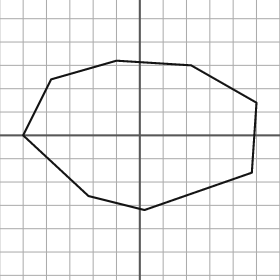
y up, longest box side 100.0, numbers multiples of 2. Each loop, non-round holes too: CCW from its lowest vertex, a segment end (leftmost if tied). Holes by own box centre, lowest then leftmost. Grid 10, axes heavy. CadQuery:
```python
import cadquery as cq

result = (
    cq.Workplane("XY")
    .moveTo(2.0, -32.0)
    .lineTo(48.0, -16.0)
    .lineTo(50.0, 14.0)
    .lineTo(22.0, 30.0)
    .lineTo(-10.0, 32.0)
    .lineTo(-38.0, 24.0)
    .lineTo(-50.0, 0.0)
    .lineTo(-22.0, -26.0)
    .close()
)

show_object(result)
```